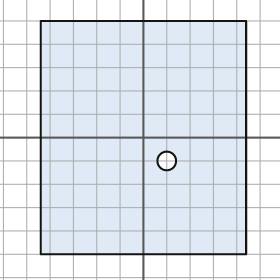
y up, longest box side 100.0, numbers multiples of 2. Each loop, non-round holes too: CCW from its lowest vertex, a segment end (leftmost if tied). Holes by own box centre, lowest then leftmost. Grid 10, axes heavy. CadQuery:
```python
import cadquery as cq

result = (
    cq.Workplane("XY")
    .moveTo(-44.0, -50.0)
    .lineTo(44.0, -50.0)
    .lineTo(44.0, 50.0)
    .lineTo(-44.0, 50.0)
    .close()
    .moveTo(10.0, -10.0)
    .circle(4.0)
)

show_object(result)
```